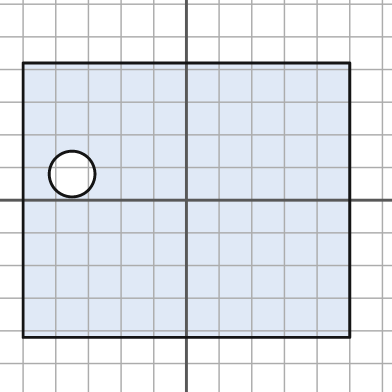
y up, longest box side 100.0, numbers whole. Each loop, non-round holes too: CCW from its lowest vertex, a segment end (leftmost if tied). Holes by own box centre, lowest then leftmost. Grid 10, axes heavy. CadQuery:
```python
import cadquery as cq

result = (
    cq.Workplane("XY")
    .moveTo(-50.0, -42.0)
    .lineTo(50.0, -42.0)
    .lineTo(50.0, 42.0)
    .lineTo(-50.0, 42.0)
    .close()
    .moveTo(-35.0, 8.0)
    .circle(7.0)
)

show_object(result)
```